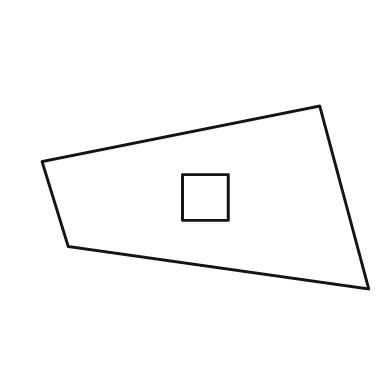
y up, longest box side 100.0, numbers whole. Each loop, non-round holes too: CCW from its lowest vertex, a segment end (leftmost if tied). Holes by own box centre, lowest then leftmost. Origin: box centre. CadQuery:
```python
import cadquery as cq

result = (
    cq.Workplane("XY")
    .moveTo(50.0, -28.0)
    .lineTo(35.0, 28.0)
    .lineTo(-50.0, 11.0)
    .lineTo(-42.0, -15.0)
    .close()
    .moveTo(-7.0, -7.0)
    .lineTo(7.0, -7.0)
    .lineTo(7.0, 7.0)
    .lineTo(-7.0, 7.0)
    .close()
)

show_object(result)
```